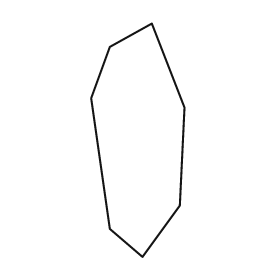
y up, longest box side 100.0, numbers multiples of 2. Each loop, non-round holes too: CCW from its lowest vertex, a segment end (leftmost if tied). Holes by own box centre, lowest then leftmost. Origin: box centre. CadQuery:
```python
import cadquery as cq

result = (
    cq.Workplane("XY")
    .moveTo(2.0, -50.0)
    .lineTo(18.0, -28.0)
    .lineTo(20.0, 14.0)
    .lineTo(6.0, 50.0)
    .lineTo(-12.0, 40.0)
    .lineTo(-20.0, 18.0)
    .lineTo(-12.0, -38.0)
    .close()
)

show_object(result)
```